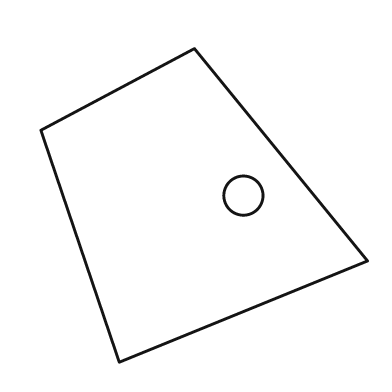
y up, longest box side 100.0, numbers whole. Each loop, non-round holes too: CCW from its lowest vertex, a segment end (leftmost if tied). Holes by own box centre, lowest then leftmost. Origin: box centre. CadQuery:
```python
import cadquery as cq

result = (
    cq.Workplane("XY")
    .moveTo(-26.0, -48.0)
    .lineTo(50.0, -17.0)
    .lineTo(-3.0, 48.0)
    .lineTo(-50.0, 23.0)
    .close()
    .moveTo(12.0, 3.0)
    .circle(6.0)
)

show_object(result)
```